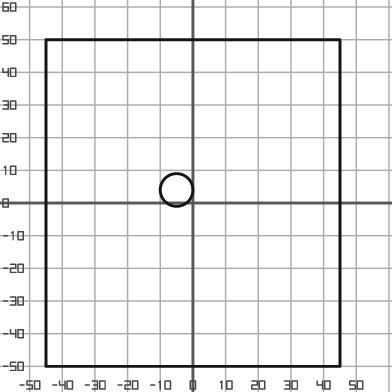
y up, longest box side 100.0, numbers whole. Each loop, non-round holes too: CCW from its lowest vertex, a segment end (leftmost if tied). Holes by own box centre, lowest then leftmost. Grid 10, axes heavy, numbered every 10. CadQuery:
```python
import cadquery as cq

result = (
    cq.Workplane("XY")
    .moveTo(-45.0, -50.0)
    .lineTo(45.0, -50.0)
    .lineTo(45.0, 50.0)
    .lineTo(-45.0, 50.0)
    .close()
    .moveTo(-5.0, 4.0)
    .circle(5.0)
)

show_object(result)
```